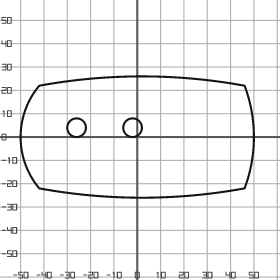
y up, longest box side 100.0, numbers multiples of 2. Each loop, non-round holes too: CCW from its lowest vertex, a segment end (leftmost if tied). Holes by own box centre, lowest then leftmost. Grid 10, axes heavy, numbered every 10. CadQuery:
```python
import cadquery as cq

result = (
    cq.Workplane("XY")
    .moveTo(-42.0, -22.0)
    .threePointArc((2.0, -26.0), (46.0, -22.0))
    .threePointArc((50.0, 0.0), (46.0, 22.0))
    .threePointArc((2.0, 26.0), (-42.0, 22.0))
    .threePointArc((-50.0, 0.0), (-42.0, -22.0))
    .close()
    .moveTo(-26.0, 4.0)
    .circle(4.0)
    .moveTo(-2.0, 4.0)
    .circle(4.0)
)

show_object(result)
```